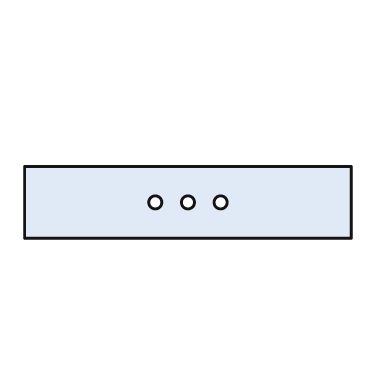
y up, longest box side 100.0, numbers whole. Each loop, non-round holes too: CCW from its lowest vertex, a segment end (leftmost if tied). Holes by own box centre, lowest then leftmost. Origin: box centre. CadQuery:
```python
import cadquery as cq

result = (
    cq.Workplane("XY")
    .moveTo(-50.0, -11.0)
    .lineTo(50.0, -11.0)
    .lineTo(50.0, 11.0)
    .lineTo(-50.0, 11.0)
    .close()
    .moveTo(-10.0, 0.0)
    .circle(2.0)
    .moveTo(0.0, 0.0)
    .circle(2.0)
    .moveTo(10.0, 0.0)
    .circle(2.0)
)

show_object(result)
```